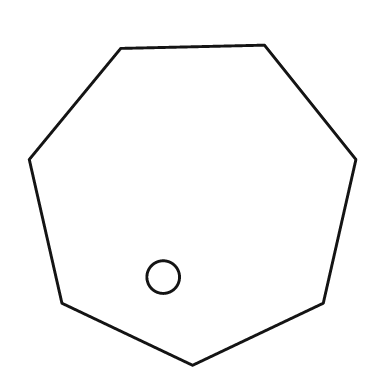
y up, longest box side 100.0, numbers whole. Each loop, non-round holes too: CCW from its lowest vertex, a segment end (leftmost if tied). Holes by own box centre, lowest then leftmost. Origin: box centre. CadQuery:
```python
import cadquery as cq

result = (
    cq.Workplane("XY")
    .moveTo(0.0, -49.0)
    .lineTo(40.0, -30.0)
    .lineTo(50.0, 14.0)
    .lineTo(22.0, 49.0)
    .lineTo(-22.0, 48.0)
    .lineTo(-50.0, 14.0)
    .lineTo(-40.0, -30.0)
    .close()
    .moveTo(-9.0, -22.0)
    .circle(5.0)
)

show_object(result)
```